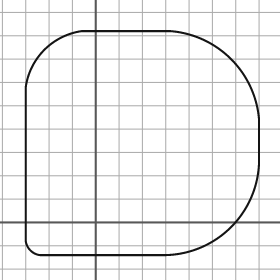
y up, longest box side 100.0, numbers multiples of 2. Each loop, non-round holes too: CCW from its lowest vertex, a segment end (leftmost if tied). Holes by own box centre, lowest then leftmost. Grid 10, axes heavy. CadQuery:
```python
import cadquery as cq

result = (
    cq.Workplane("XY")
    .moveTo(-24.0, -14.0)
    .lineTo(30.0, -14.0)
    .threePointArc((58.0, -2.0), (70.0, 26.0))
    .lineTo(70.0, 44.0)
    .threePointArc((58.0, 70.0), (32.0, 82.0))
    .lineTo(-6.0, 82.0)
    .threePointArc((-22.0, 74.0), (-30.0, 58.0))
    .lineTo(-30.0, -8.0)
    .threePointArc((-28.0, -12.0), (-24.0, -14.0))
    .close()
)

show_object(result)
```